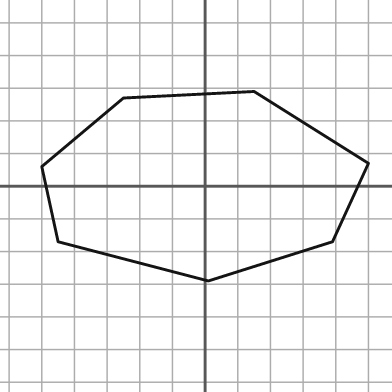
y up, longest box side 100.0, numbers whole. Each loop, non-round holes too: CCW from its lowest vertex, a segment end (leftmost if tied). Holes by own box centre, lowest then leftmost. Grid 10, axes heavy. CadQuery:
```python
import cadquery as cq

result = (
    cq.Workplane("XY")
    .moveTo(1.0, -29.0)
    .lineTo(39.0, -17.0)
    .lineTo(50.0, 7.0)
    .lineTo(15.0, 29.0)
    .lineTo(-25.0, 27.0)
    .lineTo(-50.0, 6.0)
    .lineTo(-45.0, -17.0)
    .close()
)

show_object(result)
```